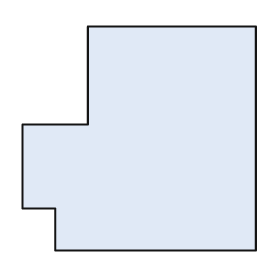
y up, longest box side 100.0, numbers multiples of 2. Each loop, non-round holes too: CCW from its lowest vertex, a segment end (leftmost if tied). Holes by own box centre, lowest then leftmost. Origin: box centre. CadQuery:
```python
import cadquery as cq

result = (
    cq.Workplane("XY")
    .moveTo(-36.0, -48.0)
    .lineTo(50.0, -48.0)
    .lineTo(50.0, 48.0)
    .lineTo(-22.0, 48.0)
    .lineTo(-22.0, 6.0)
    .lineTo(-50.0, 6.0)
    .lineTo(-50.0, -30.0)
    .lineTo(-36.0, -30.0)
    .close()
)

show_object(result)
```